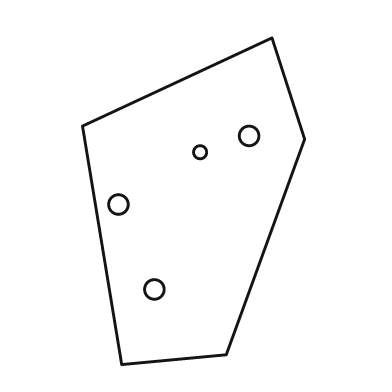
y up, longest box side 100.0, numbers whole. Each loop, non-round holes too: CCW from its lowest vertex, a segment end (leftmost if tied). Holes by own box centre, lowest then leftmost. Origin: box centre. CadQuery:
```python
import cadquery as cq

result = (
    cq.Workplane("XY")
    .moveTo(-22.0, -50.0)
    .lineTo(10.0, -47.0)
    .lineTo(34.0, 19.0)
    .lineTo(24.0, 50.0)
    .lineTo(-34.0, 23.0)
    .close()
    .moveTo(-12.0, -27.0)
    .circle(3.0)
    .moveTo(-23.0, -1.0)
    .circle(3.0)
    .moveTo(2.0, 15.0)
    .circle(2.0)
    .moveTo(17.0, 20.0)
    .circle(3.0)
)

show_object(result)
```